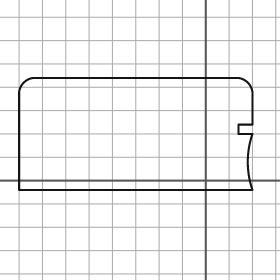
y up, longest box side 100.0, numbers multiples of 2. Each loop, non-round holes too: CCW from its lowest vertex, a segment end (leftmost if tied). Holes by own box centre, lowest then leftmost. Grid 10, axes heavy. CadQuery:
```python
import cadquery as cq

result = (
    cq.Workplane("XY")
    .moveTo(-80.0, -4.0)
    .lineTo(20.0, -4.0)
    .threePointArc((18.0, 8.0), (20.0, 20.0))
    .lineTo(14.0, 20.0)
    .lineTo(14.0, 24.0)
    .lineTo(20.0, 24.0)
    .lineTo(20.0, 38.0)
    .threePointArc((18.0, 42.0), (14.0, 44.0))
    .lineTo(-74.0, 44.0)
    .threePointArc((-78.0, 42.0), (-80.0, 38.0))
    .close()
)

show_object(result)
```